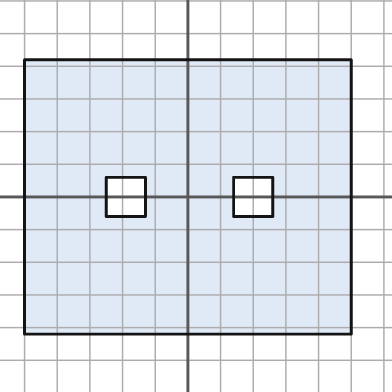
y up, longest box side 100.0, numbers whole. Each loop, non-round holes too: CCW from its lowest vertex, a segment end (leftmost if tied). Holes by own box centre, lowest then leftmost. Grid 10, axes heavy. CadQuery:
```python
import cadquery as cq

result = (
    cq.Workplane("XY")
    .moveTo(-50.0, -42.0)
    .lineTo(50.0, -42.0)
    .lineTo(50.0, 42.0)
    .lineTo(-50.0, 42.0)
    .close()
    .moveTo(-25.0, -6.0)
    .lineTo(-13.0, -6.0)
    .lineTo(-13.0, 6.0)
    .lineTo(-25.0, 6.0)
    .close()
    .moveTo(14.0, -6.0)
    .lineTo(26.0, -6.0)
    .lineTo(26.0, 6.0)
    .lineTo(14.0, 6.0)
    .close()
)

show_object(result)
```